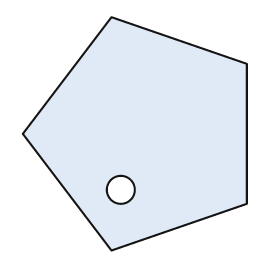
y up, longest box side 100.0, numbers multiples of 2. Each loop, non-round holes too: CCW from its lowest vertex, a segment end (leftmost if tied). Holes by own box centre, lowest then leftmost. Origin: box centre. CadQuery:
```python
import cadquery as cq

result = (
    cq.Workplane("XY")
    .moveTo(-10.0, -50.0)
    .lineTo(48.0, -30.0)
    .lineTo(48.0, 30.0)
    .lineTo(-10.0, 50.0)
    .lineTo(-48.0, 0.0)
    .close()
    .moveTo(-6.0, -24.0)
    .circle(6.0)
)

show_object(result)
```